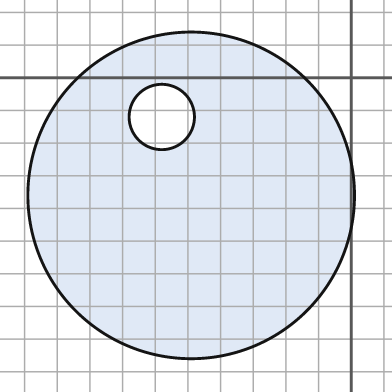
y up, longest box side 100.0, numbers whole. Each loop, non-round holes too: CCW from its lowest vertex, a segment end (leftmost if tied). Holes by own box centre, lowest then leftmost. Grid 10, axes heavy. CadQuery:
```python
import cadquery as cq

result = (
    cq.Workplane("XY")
    .moveTo(-49.0, -36.0)
    .circle(50.0)
    .moveTo(-58.0, -12.0)
    .circle(10.0)
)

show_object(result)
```